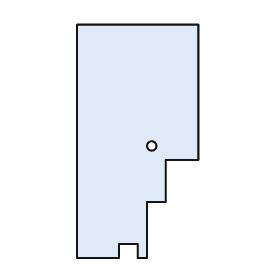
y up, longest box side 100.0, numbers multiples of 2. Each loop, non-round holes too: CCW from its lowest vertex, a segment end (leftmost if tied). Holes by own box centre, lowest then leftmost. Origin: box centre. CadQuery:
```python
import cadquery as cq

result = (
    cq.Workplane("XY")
    .moveTo(-26.0, -50.0)
    .lineTo(-8.0, -50.0)
    .lineTo(-8.0, -44.0)
    .lineTo(0.0, -44.0)
    .lineTo(0.0, -50.0)
    .lineTo(4.0, -50.0)
    .lineTo(4.0, -26.0)
    .lineTo(12.0, -26.0)
    .lineTo(12.0, -8.0)
    .lineTo(26.0, -8.0)
    .lineTo(26.0, 50.0)
    .lineTo(-26.0, 50.0)
    .close()
    .moveTo(6.0, -2.0)
    .circle(2.0)
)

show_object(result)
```